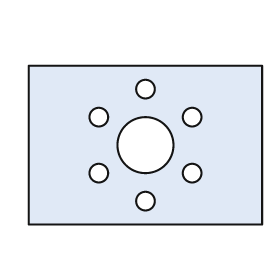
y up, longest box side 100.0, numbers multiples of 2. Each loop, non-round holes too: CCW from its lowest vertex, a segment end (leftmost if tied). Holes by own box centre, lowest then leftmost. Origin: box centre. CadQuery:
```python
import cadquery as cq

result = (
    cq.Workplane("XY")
    .moveTo(-50.0, -34.0)
    .lineTo(50.0, -34.0)
    .lineTo(50.0, 34.0)
    .lineTo(-50.0, 34.0)
    .close()
    .moveTo(0.0, -24.0)
    .circle(4.0)
    .moveTo(-20.0, -12.0)
    .circle(4.0)
    .moveTo(20.0, -12.0)
    .circle(4.0)
    .moveTo(0.0, 0.0)
    .circle(12.0)
    .moveTo(-20.0, 12.0)
    .circle(4.0)
    .moveTo(20.0, 12.0)
    .circle(4.0)
    .moveTo(0.0, 24.0)
    .circle(4.0)
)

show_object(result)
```